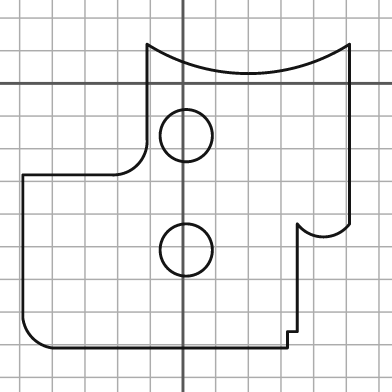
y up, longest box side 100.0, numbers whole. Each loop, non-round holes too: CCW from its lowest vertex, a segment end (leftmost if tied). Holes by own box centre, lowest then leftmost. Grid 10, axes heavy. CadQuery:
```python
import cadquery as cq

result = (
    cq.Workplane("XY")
    .moveTo(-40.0, -81.0)
    .lineTo(32.0, -81.0)
    .lineTo(32.0, -76.0)
    .lineTo(35.0, -76.0)
    .lineTo(35.0, -43.0)
    .threePointArc((43.0, -47.0), (51.0, -43.0))
    .lineTo(51.0, 12.0)
    .threePointArc((20.0, 3.0), (-11.0, 12.0))
    .lineTo(-11.0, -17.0)
    .threePointArc((-14.0, -25.0), (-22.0, -28.0))
    .lineTo(-49.0, -28.0)
    .lineTo(-49.0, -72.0)
    .threePointArc((-46.0, -78.0), (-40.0, -81.0))
    .close()
    .moveTo(1.0, -51.0)
    .circle(8.0)
    .moveTo(1.0, -16.0)
    .circle(8.0)
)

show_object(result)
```